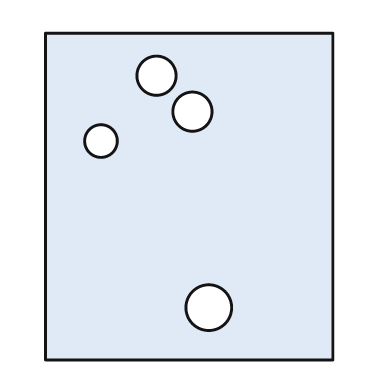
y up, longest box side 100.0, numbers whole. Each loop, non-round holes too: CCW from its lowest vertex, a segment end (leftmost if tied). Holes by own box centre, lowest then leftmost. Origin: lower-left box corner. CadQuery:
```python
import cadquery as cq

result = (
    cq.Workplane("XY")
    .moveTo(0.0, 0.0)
    .lineTo(88.0, 0.0)
    .lineTo(88.0, 100.0)
    .lineTo(0.0, 100.0)
    .close()
    .moveTo(50.0, 16.0)
    .circle(7.0)
    .moveTo(17.0, 67.0)
    .circle(5.0)
    .moveTo(45.0, 76.0)
    .circle(6.0)
    .moveTo(34.0, 87.0)
    .circle(6.0)
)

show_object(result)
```